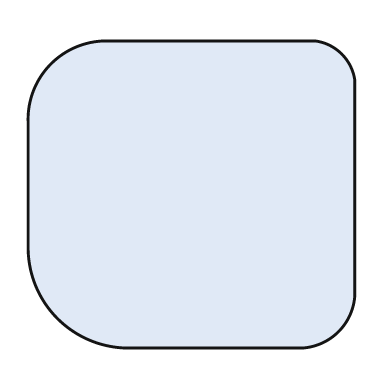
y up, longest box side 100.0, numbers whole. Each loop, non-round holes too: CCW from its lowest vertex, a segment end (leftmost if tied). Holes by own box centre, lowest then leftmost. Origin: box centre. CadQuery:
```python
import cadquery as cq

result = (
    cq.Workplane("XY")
    .moveTo(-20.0, -47.0)
    .lineTo(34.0, -47.0)
    .threePointArc((45.0, -42.0), (50.0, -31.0))
    .lineTo(50.0, 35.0)
    .threePointArc((46.0, 43.0), (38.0, 47.0))
    .lineTo(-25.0, 47.0)
    .threePointArc((-43.0, 40.0), (-50.0, 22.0))
    .lineTo(-50.0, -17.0)
    .threePointArc((-41.0, -38.0), (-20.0, -47.0))
    .close()
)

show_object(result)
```